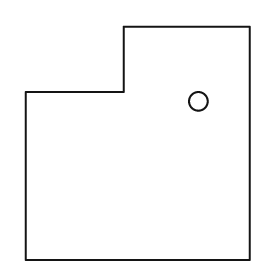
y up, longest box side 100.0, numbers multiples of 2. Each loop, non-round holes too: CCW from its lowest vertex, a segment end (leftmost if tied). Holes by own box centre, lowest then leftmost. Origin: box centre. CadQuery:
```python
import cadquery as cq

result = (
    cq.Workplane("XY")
    .moveTo(-48.0, -50.0)
    .lineTo(48.0, -50.0)
    .lineTo(48.0, 50.0)
    .lineTo(-6.0, 50.0)
    .lineTo(-6.0, 22.0)
    .lineTo(-48.0, 22.0)
    .close()
    .moveTo(26.0, 18.0)
    .circle(4.0)
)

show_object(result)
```